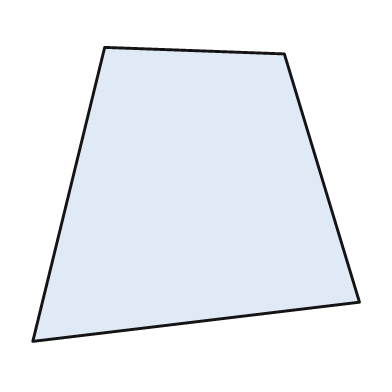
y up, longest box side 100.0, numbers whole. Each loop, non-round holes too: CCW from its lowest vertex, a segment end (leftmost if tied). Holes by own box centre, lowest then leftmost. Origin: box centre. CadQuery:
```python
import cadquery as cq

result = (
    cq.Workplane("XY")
    .moveTo(-50.0, -45.0)
    .lineTo(50.0, -33.0)
    .lineTo(27.0, 43.0)
    .lineTo(-28.0, 45.0)
    .close()
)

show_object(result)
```